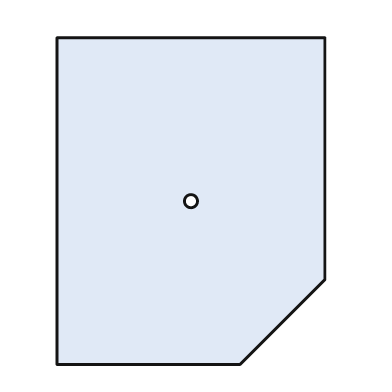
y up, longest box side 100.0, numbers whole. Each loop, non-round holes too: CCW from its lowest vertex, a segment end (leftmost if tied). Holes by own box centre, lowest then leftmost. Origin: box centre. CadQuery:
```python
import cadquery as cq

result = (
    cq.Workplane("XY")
    .moveTo(-41.0, -50.0)
    .lineTo(15.0, -50.0)
    .lineTo(41.0, -24.0)
    .lineTo(41.0, 50.0)
    .lineTo(-41.0, 50.0)
    .close()
    .moveTo(0.0, 0.0)
    .circle(2.0)
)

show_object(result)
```